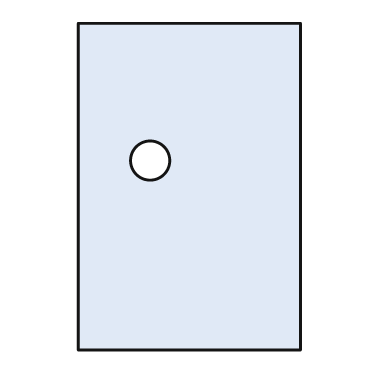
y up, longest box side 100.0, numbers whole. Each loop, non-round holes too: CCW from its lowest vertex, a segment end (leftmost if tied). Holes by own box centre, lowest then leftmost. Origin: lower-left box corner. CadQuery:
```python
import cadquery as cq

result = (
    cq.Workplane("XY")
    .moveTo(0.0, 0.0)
    .lineTo(68.0, 0.0)
    .lineTo(68.0, 100.0)
    .lineTo(0.0, 100.0)
    .close()
    .moveTo(22.0, 58.0)
    .circle(6.0)
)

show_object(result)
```